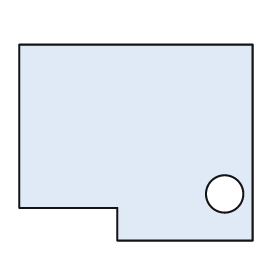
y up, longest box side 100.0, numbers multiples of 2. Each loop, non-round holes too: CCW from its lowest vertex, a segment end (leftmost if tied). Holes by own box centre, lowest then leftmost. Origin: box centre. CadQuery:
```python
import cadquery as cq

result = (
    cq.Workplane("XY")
    .moveTo(-8.0, -42.0)
    .lineTo(50.0, -42.0)
    .lineTo(50.0, 42.0)
    .lineTo(-50.0, 42.0)
    .lineTo(-50.0, -28.0)
    .lineTo(-8.0, -28.0)
    .close()
    .moveTo(38.0, -22.0)
    .circle(8.0)
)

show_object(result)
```